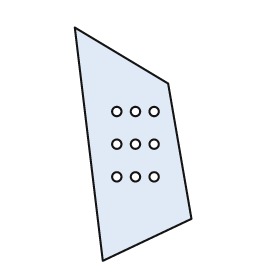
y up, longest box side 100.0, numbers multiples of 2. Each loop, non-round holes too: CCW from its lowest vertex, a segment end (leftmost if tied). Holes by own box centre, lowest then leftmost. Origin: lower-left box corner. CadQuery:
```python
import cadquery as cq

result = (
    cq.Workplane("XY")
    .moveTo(12.0, 0.0)
    .lineTo(50.0, 18.0)
    .lineTo(40.0, 76.0)
    .lineTo(0.0, 100.0)
    .close()
    .moveTo(18.0, 36.0)
    .circle(2.0)
    .moveTo(26.0, 36.0)
    .circle(2.0)
    .moveTo(34.0, 36.0)
    .circle(2.0)
    .moveTo(18.0, 50.0)
    .circle(2.0)
    .moveTo(26.0, 50.0)
    .circle(2.0)
    .moveTo(34.0, 50.0)
    .circle(2.0)
    .moveTo(18.0, 64.0)
    .circle(2.0)
    .moveTo(26.0, 64.0)
    .circle(2.0)
    .moveTo(34.0, 64.0)
    .circle(2.0)
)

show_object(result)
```